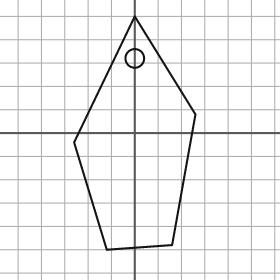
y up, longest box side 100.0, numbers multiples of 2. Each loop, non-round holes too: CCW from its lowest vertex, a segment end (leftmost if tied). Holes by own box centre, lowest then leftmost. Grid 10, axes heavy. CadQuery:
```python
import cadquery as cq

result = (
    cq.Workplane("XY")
    .moveTo(-12.0, -50.0)
    .lineTo(16.0, -48.0)
    .lineTo(26.0, 8.0)
    .lineTo(0.0, 50.0)
    .lineTo(-26.0, -4.0)
    .close()
    .moveTo(0.0, 32.0)
    .circle(4.0)
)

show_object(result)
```